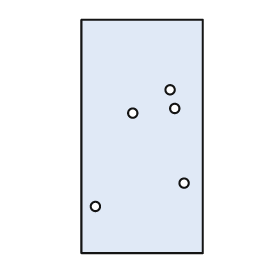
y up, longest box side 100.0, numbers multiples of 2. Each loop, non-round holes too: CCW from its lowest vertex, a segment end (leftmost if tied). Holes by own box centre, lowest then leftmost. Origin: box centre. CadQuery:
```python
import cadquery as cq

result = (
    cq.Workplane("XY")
    .moveTo(-26.0, -50.0)
    .lineTo(26.0, -50.0)
    .lineTo(26.0, 50.0)
    .lineTo(-26.0, 50.0)
    .close()
    .moveTo(-20.0, -30.0)
    .circle(2.0)
    .moveTo(18.0, -20.0)
    .circle(2.0)
    .moveTo(-4.0, 10.0)
    .circle(2.0)
    .moveTo(14.0, 12.0)
    .circle(2.0)
    .moveTo(12.0, 20.0)
    .circle(2.0)
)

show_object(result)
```